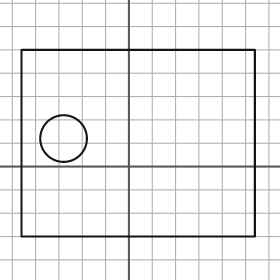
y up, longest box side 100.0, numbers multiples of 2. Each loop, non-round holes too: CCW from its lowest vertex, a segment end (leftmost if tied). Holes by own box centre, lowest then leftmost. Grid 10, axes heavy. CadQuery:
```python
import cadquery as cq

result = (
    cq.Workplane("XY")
    .moveTo(-46.0, -30.0)
    .lineTo(54.0, -30.0)
    .lineTo(54.0, 50.0)
    .lineTo(-46.0, 50.0)
    .close()
    .moveTo(-28.0, 12.0)
    .circle(10.0)
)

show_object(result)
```